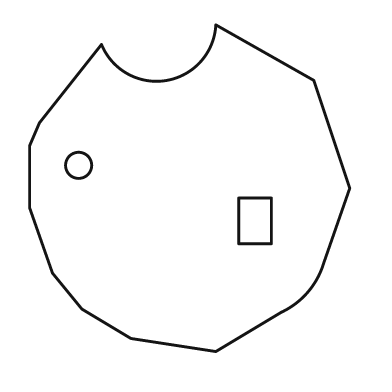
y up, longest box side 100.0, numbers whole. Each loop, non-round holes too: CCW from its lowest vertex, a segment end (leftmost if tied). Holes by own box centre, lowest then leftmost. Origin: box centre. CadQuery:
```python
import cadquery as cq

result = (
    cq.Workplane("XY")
    .moveTo(8.0, -50.0)
    .lineTo(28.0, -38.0)
    .threePointArc((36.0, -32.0), (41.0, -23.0))
    .lineTo(49.0, 0.0)
    .lineTo(38.0, 33.0)
    .lineTo(8.0, 50.0)
    .threePointArc((-7.0, 33.0), (-27.0, 44.0))
    .lineTo(-46.0, 20.0)
    .lineTo(-49.0, 13.0)
    .lineTo(-49.0, -6.0)
    .lineTo(-42.0, -26.0)
    .lineTo(-33.0, -37.0)
    .lineTo(-18.0, -46.0)
    .close()
    .moveTo(15.0, -17.0)
    .lineTo(25.0, -17.0)
    .lineTo(25.0, -3.0)
    .lineTo(15.0, -3.0)
    .close()
    .moveTo(-34.0, 7.0)
    .circle(4.0)
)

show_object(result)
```